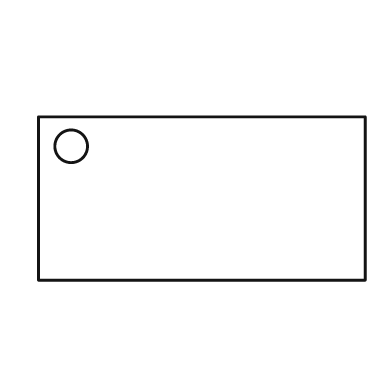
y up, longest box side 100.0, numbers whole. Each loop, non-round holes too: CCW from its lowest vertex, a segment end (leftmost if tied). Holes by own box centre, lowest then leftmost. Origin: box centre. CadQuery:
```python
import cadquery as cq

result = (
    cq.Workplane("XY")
    .moveTo(-50.0, -25.0)
    .lineTo(50.0, -25.0)
    .lineTo(50.0, 25.0)
    .lineTo(-50.0, 25.0)
    .close()
    .moveTo(-40.0, 16.0)
    .circle(5.0)
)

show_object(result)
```